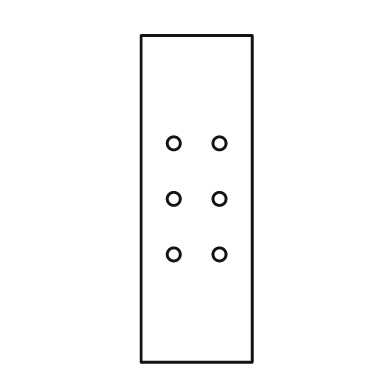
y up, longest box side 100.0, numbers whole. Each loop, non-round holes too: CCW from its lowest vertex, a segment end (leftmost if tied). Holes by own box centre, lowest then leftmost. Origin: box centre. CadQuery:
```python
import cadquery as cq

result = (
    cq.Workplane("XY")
    .moveTo(-17.0, -50.0)
    .lineTo(17.0, -50.0)
    .lineTo(17.0, 50.0)
    .lineTo(-17.0, 50.0)
    .close()
    .moveTo(-7.0, -17.0)
    .circle(2.0)
    .moveTo(7.0, -17.0)
    .circle(2.0)
    .moveTo(-7.0, 0.0)
    .circle(2.0)
    .moveTo(7.0, 0.0)
    .circle(2.0)
    .moveTo(-7.0, 17.0)
    .circle(2.0)
    .moveTo(7.0, 17.0)
    .circle(2.0)
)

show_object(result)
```